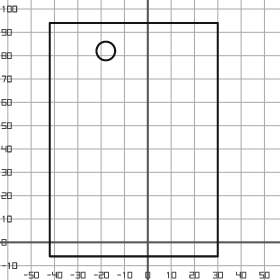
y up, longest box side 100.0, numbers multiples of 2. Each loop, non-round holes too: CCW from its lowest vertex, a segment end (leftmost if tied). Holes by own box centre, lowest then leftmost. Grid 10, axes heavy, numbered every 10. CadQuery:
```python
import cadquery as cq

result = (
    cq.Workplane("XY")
    .moveTo(-42.0, -6.0)
    .lineTo(30.0, -6.0)
    .lineTo(30.0, 94.0)
    .lineTo(-42.0, 94.0)
    .close()
    .moveTo(-18.0, 82.0)
    .circle(4.0)
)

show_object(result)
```